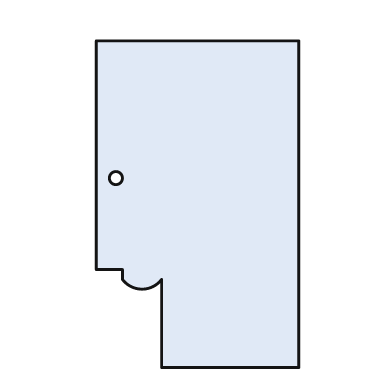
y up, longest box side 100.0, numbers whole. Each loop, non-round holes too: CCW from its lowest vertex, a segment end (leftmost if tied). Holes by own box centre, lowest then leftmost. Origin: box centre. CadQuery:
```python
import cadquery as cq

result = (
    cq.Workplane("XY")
    .moveTo(-11.0, -50.0)
    .lineTo(31.0, -50.0)
    .lineTo(31.0, 50.0)
    .lineTo(-31.0, 50.0)
    .lineTo(-31.0, -20.0)
    .lineTo(-23.0, -20.0)
    .lineTo(-23.0, -23.0)
    .threePointArc((-17.0, -26.0), (-11.0, -23.0))
    .close()
    .moveTo(-25.0, 8.0)
    .circle(2.0)
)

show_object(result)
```